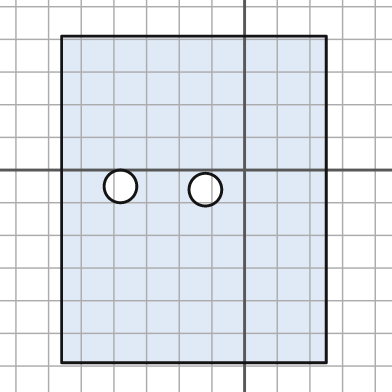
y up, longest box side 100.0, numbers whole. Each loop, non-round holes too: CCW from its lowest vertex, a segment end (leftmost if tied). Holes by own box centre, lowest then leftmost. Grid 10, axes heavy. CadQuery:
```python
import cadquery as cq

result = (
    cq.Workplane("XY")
    .moveTo(-56.0, -59.0)
    .lineTo(25.0, -59.0)
    .lineTo(25.0, 41.0)
    .lineTo(-56.0, 41.0)
    .close()
    .moveTo(-12.0, -6.0)
    .circle(5.0)
    .moveTo(-38.0, -5.0)
    .circle(5.0)
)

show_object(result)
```